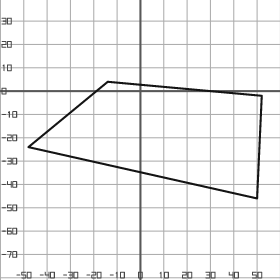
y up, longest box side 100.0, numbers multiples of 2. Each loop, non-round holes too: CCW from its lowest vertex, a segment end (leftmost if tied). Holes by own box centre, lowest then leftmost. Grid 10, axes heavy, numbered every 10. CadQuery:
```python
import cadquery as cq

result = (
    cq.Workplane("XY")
    .moveTo(50.0, -46.0)
    .lineTo(52.0, -2.0)
    .lineTo(-14.0, 4.0)
    .lineTo(-48.0, -24.0)
    .close()
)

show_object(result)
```